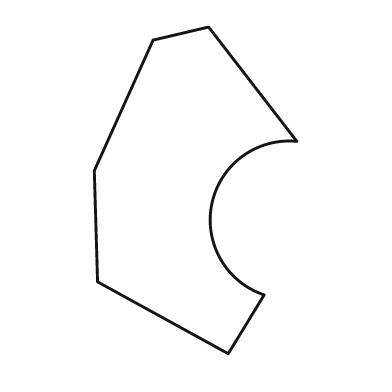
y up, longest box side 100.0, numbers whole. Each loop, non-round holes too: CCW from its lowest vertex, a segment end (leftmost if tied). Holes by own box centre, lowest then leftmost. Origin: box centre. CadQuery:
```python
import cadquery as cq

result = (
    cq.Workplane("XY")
    .moveTo(10.0, -50.0)
    .lineTo(21.0, -32.0)
    .threePointArc((5.0, -4.0), (31.0, 15.0))
    .lineTo(4.0, 50.0)
    .lineTo(-13.0, 46.0)
    .lineTo(-31.0, 6.0)
    .lineTo(-30.0, -28.0)
    .close()
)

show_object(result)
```